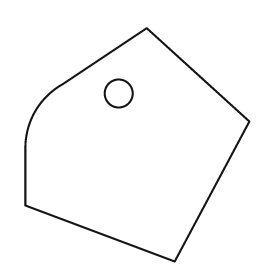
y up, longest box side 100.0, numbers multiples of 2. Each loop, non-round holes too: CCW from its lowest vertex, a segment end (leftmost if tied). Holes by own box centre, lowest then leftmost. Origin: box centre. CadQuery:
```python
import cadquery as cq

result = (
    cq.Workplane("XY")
    .moveTo(16.0, -50.0)
    .lineTo(48.0, 10.0)
    .lineTo(4.0, 50.0)
    .lineTo(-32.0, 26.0)
    .threePointArc((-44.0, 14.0), (-48.0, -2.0))
    .lineTo(-48.0, -26.0)
    .close()
    .moveTo(-8.0, 22.0)
    .circle(6.0)
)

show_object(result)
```